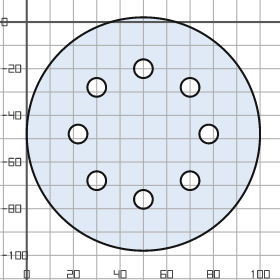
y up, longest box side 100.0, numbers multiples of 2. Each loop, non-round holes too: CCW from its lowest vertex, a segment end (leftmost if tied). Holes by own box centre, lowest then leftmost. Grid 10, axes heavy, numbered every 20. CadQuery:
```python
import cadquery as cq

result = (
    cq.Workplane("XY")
    .moveTo(50.0, -48.0)
    .circle(50.0)
    .moveTo(50.0, -76.0)
    .circle(4.0)
    .moveTo(30.0, -68.0)
    .circle(4.0)
    .moveTo(70.0, -68.0)
    .circle(4.0)
    .moveTo(22.0, -48.0)
    .circle(4.0)
    .moveTo(78.0, -48.0)
    .circle(4.0)
    .moveTo(30.0, -28.0)
    .circle(4.0)
    .moveTo(70.0, -28.0)
    .circle(4.0)
    .moveTo(50.0, -20.0)
    .circle(4.0)
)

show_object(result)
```